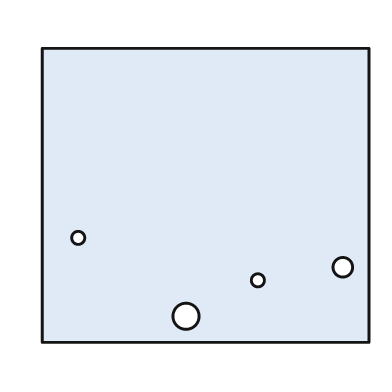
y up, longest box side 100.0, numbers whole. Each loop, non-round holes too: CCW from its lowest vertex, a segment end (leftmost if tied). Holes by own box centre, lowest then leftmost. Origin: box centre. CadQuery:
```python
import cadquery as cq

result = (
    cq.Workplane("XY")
    .moveTo(-50.0, -45.0)
    .lineTo(50.0, -45.0)
    .lineTo(50.0, 45.0)
    .lineTo(-50.0, 45.0)
    .close()
    .moveTo(-6.0, -37.0)
    .circle(4.0)
    .moveTo(16.0, -26.0)
    .circle(2.0)
    .moveTo(42.0, -22.0)
    .circle(3.0)
    .moveTo(-39.0, -13.0)
    .circle(2.0)
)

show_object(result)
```